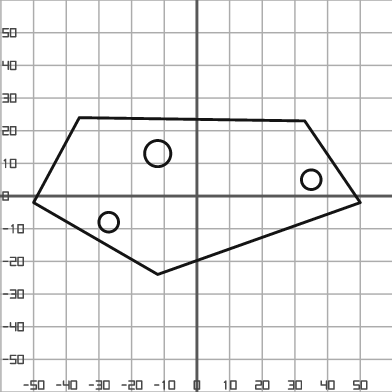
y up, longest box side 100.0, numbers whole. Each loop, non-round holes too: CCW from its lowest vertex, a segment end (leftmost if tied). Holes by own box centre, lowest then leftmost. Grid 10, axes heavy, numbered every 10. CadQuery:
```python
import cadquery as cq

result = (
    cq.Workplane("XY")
    .moveTo(-12.0, -24.0)
    .lineTo(50.0, -2.0)
    .lineTo(33.0, 23.0)
    .lineTo(-36.0, 24.0)
    .lineTo(-50.0, -2.0)
    .close()
    .moveTo(-27.0, -8.0)
    .circle(3.0)
    .moveTo(35.0, 5.0)
    .circle(3.0)
    .moveTo(-12.0, 13.0)
    .circle(4.0)
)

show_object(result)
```